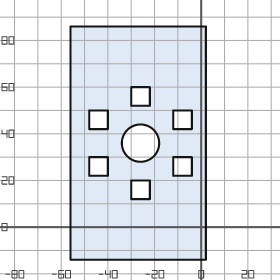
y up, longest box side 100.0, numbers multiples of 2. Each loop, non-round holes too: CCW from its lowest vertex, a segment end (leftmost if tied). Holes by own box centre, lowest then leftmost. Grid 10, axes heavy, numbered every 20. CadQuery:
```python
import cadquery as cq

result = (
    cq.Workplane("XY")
    .moveTo(-56.0, -14.0)
    .lineTo(2.0, -14.0)
    .lineTo(2.0, 86.0)
    .lineTo(-56.0, 86.0)
    .close()
    .moveTo(-30.0, 12.0)
    .lineTo(-22.0, 12.0)
    .lineTo(-22.0, 20.0)
    .lineTo(-30.0, 20.0)
    .close()
    .moveTo(-48.0, 22.0)
    .lineTo(-40.0, 22.0)
    .lineTo(-40.0, 30.0)
    .lineTo(-48.0, 30.0)
    .close()
    .moveTo(-12.0, 22.0)
    .lineTo(-4.0, 22.0)
    .lineTo(-4.0, 30.0)
    .lineTo(-12.0, 30.0)
    .close()
    .moveTo(-26.0, 36.0)
    .circle(8.0)
    .moveTo(-48.0, 42.0)
    .lineTo(-40.0, 42.0)
    .lineTo(-40.0, 50.0)
    .lineTo(-48.0, 50.0)
    .close()
    .moveTo(-12.0, 42.0)
    .lineTo(-4.0, 42.0)
    .lineTo(-4.0, 50.0)
    .lineTo(-12.0, 50.0)
    .close()
    .moveTo(-30.0, 52.0)
    .lineTo(-22.0, 52.0)
    .lineTo(-22.0, 60.0)
    .lineTo(-30.0, 60.0)
    .close()
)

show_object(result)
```